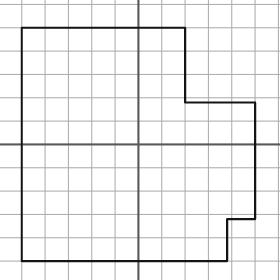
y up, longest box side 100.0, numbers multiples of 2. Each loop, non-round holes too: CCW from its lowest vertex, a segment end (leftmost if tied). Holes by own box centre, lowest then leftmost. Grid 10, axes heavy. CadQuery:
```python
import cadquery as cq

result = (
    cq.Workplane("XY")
    .moveTo(-50.0, -50.0)
    .lineTo(38.0, -50.0)
    .lineTo(38.0, -32.0)
    .lineTo(50.0, -32.0)
    .lineTo(50.0, 18.0)
    .lineTo(20.0, 18.0)
    .lineTo(20.0, 50.0)
    .lineTo(-50.0, 50.0)
    .close()
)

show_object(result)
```